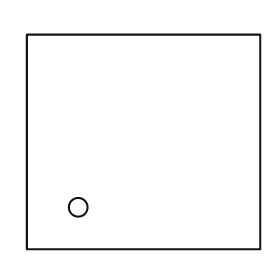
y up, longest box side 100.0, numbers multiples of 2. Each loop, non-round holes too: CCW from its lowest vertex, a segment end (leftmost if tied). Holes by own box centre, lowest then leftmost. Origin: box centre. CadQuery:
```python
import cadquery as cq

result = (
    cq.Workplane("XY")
    .moveTo(-50.0, -46.0)
    .lineTo(50.0, -46.0)
    .lineTo(50.0, 46.0)
    .lineTo(-50.0, 46.0)
    .close()
    .moveTo(-28.0, -28.0)
    .circle(4.0)
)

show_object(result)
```